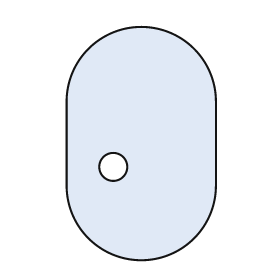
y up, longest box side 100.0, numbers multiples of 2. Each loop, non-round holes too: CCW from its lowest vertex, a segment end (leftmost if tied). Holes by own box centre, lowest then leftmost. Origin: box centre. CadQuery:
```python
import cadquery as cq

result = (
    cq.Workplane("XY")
    .moveTo(-32.0, -18.0)
    .threePointArc((0.0, -50.0), (32.0, -18.0))
    .lineTo(32.0, 18.0)
    .threePointArc((0.0, 50.0), (-32.0, 18.0))
    .close()
    .moveTo(-12.0, -10.0)
    .circle(6.0)
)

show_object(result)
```